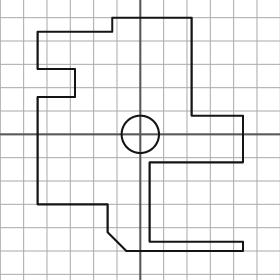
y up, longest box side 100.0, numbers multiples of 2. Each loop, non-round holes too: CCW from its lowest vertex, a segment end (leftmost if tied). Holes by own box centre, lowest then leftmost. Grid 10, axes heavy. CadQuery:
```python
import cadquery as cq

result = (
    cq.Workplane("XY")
    .moveTo(-6.0, -50.0)
    .lineTo(44.0, -50.0)
    .lineTo(44.0, -46.0)
    .lineTo(4.0, -46.0)
    .lineTo(4.0, -12.0)
    .lineTo(44.0, -12.0)
    .lineTo(44.0, 8.0)
    .lineTo(22.0, 8.0)
    .lineTo(22.0, 50.0)
    .lineTo(-12.0, 50.0)
    .lineTo(-12.0, 44.0)
    .lineTo(-44.0, 44.0)
    .lineTo(-44.0, 28.0)
    .lineTo(-28.0, 28.0)
    .lineTo(-28.0, 16.0)
    .lineTo(-44.0, 16.0)
    .lineTo(-44.0, -30.0)
    .lineTo(-14.0, -30.0)
    .lineTo(-14.0, -42.0)
    .close()
    .moveTo(0.0, 0.0)
    .circle(8.0)
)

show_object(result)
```